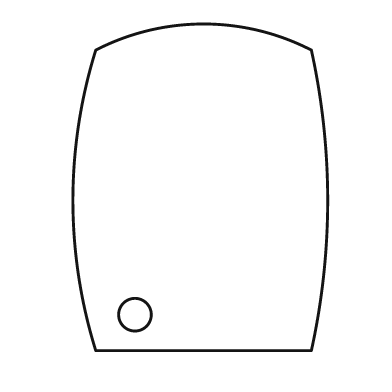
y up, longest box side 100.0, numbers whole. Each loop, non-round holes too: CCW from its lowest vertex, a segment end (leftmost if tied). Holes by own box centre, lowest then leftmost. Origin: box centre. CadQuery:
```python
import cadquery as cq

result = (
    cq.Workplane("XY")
    .moveTo(-32.0, -50.0)
    .lineTo(34.0, -50.0)
    .threePointArc((39.0, -4.0), (34.0, 42.0))
    .threePointArc((1.0, 50.0), (-32.0, 42.0))
    .threePointArc((-39.0, -4.0), (-32.0, -50.0))
    .close()
    .moveTo(-20.0, -39.0)
    .circle(5.0)
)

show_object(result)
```